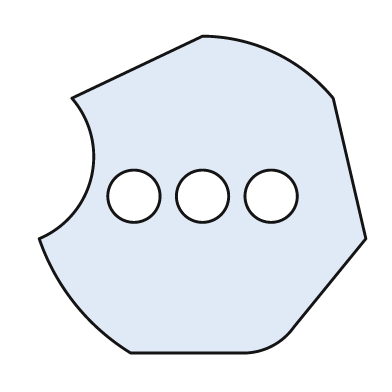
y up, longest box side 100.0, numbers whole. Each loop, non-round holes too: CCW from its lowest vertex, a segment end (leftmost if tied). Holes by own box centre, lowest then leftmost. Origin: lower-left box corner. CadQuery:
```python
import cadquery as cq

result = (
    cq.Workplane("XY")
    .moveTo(28.0, 0.0)
    .lineTo(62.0, 0.0)
    .threePointArc((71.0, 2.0), (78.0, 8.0))
    .lineTo(100.0, 35.0)
    .lineTo(90.0, 78.0)
    .threePointArc((72.0, 92.0), (50.0, 97.0))
    .lineTo(10.0, 78.0)
    .threePointArc((16.0, 54.0), (0.0, 35.0))
    .threePointArc((11.0, 15.0), (28.0, 0.0))
    .close()
    .moveTo(29.0, 48.0)
    .circle(8.0)
    .moveTo(50.0, 48.0)
    .circle(8.0)
    .moveTo(71.0, 48.0)
    .circle(8.0)
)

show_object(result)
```